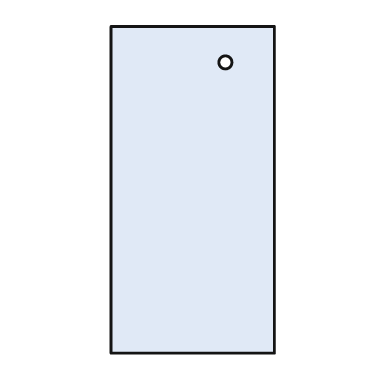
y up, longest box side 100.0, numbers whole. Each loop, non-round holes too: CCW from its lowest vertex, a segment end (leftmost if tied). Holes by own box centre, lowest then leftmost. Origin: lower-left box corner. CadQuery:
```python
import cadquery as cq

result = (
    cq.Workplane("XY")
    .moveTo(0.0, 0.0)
    .lineTo(50.0, 0.0)
    .lineTo(50.0, 100.0)
    .lineTo(0.0, 100.0)
    .close()
    .moveTo(35.0, 89.0)
    .circle(2.0)
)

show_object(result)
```